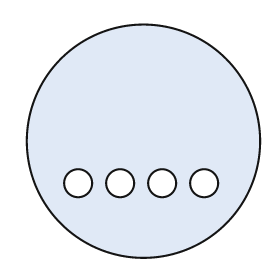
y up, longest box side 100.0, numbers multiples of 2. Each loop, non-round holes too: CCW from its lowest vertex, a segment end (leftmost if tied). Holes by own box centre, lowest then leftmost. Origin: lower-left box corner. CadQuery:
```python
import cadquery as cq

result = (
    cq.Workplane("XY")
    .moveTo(50.0, 50.0)
    .circle(50.0)
    .moveTo(22.0, 32.0)
    .circle(6.0)
    .moveTo(40.0, 32.0)
    .circle(6.0)
    .moveTo(58.0, 32.0)
    .circle(6.0)
    .moveTo(76.0, 32.0)
    .circle(6.0)
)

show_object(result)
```